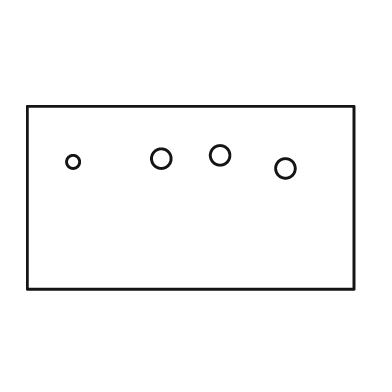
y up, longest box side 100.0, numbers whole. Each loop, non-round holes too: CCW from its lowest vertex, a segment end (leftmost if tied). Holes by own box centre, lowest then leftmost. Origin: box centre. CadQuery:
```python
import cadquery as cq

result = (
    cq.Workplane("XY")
    .moveTo(-50.0, -28.0)
    .lineTo(50.0, -28.0)
    .lineTo(50.0, 28.0)
    .lineTo(-50.0, 28.0)
    .close()
    .moveTo(29.0, 9.0)
    .circle(3.0)
    .moveTo(-36.0, 11.0)
    .circle(2.0)
    .moveTo(-9.0, 12.0)
    .circle(3.0)
    .moveTo(9.0, 13.0)
    .circle(3.0)
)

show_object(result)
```